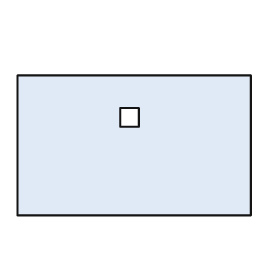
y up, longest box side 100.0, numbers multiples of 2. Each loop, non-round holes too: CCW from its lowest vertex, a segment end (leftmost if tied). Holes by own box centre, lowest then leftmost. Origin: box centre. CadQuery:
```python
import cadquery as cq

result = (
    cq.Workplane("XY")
    .moveTo(-50.0, -30.0)
    .lineTo(50.0, -30.0)
    .lineTo(50.0, 30.0)
    .lineTo(-50.0, 30.0)
    .close()
    .moveTo(-6.0, 8.0)
    .lineTo(2.0, 8.0)
    .lineTo(2.0, 16.0)
    .lineTo(-6.0, 16.0)
    .close()
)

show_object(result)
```